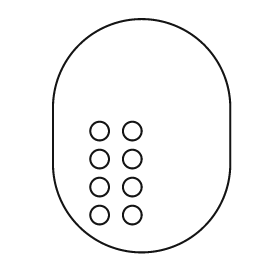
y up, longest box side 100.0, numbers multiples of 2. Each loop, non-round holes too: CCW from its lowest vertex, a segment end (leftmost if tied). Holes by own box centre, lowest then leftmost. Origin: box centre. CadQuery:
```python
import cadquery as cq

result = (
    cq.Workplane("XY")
    .moveTo(-38.0, -12.0)
    .threePointArc((0.0, -50.0), (38.0, -12.0))
    .lineTo(38.0, 12.0)
    .threePointArc((0.0, 50.0), (-38.0, 12.0))
    .close()
    .moveTo(-18.0, -34.0)
    .circle(4.0)
    .moveTo(-4.0, -34.0)
    .circle(4.0)
    .moveTo(-18.0, -22.0)
    .circle(4.0)
    .moveTo(-4.0, -22.0)
    .circle(4.0)
    .moveTo(-18.0, -10.0)
    .circle(4.0)
    .moveTo(-4.0, -10.0)
    .circle(4.0)
    .moveTo(-18.0, 2.0)
    .circle(4.0)
    .moveTo(-4.0, 2.0)
    .circle(4.0)
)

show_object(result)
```